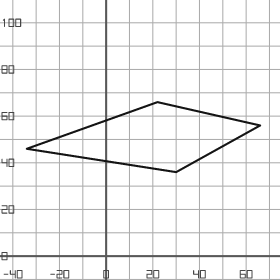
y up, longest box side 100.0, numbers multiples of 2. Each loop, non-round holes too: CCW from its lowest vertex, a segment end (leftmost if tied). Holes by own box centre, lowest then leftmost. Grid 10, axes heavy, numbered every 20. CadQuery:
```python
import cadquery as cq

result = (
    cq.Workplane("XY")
    .moveTo(30.0, 36.0)
    .lineTo(66.0, 56.0)
    .lineTo(22.0, 66.0)
    .lineTo(-34.0, 46.0)
    .close()
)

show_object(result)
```